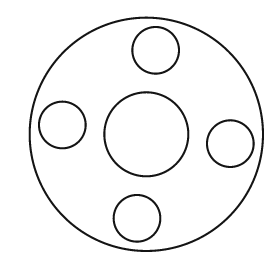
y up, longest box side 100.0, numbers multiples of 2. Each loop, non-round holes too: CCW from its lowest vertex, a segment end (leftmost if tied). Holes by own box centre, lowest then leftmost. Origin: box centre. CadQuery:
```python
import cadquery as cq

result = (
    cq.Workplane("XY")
    .moveTo(0.0, 0.0)
    .circle(50.0)
    .moveTo(-4.0, -36.0)
    .circle(10.0)
    .moveTo(36.0, -4.0)
    .circle(10.0)
    .moveTo(0.0, 0.0)
    .circle(18.0)
    .moveTo(-36.0, 4.0)
    .circle(10.0)
    .moveTo(4.0, 36.0)
    .circle(10.0)
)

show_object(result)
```